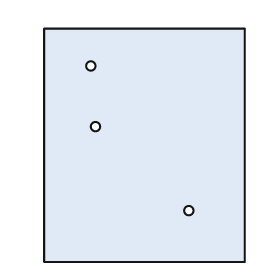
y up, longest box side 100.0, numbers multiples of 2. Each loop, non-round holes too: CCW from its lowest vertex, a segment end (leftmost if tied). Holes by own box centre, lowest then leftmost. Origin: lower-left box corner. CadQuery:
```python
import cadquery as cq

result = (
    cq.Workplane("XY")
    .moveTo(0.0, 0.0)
    .lineTo(86.0, 0.0)
    .lineTo(86.0, 100.0)
    .lineTo(0.0, 100.0)
    .close()
    .moveTo(62.0, 22.0)
    .circle(2.0)
    .moveTo(22.0, 58.0)
    .circle(2.0)
    .moveTo(20.0, 84.0)
    .circle(2.0)
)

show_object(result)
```